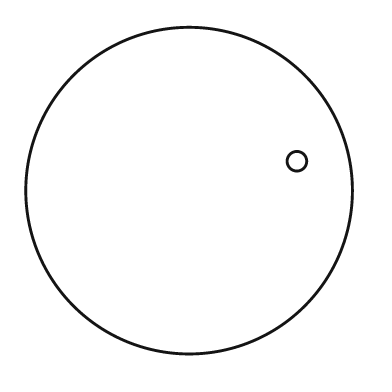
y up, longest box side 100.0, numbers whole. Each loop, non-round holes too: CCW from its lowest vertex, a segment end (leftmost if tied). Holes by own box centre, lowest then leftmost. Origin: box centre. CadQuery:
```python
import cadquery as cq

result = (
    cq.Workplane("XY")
    .moveTo(0.0, 0.0)
    .circle(50.0)
    .moveTo(33.0, 9.0)
    .circle(3.0)
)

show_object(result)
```